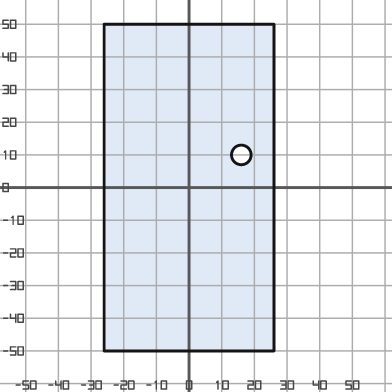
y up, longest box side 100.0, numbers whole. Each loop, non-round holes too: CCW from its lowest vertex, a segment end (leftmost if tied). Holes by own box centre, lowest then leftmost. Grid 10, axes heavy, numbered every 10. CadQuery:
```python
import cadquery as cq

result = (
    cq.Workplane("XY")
    .moveTo(-26.0, -50.0)
    .lineTo(26.0, -50.0)
    .lineTo(26.0, 50.0)
    .lineTo(-26.0, 50.0)
    .close()
    .moveTo(16.0, 10.0)
    .circle(3.0)
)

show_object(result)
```